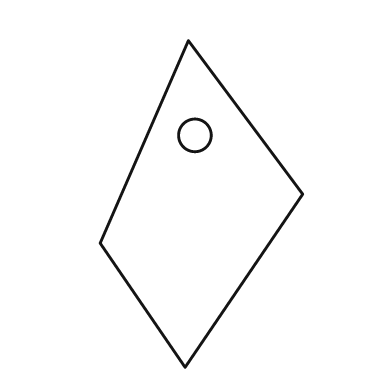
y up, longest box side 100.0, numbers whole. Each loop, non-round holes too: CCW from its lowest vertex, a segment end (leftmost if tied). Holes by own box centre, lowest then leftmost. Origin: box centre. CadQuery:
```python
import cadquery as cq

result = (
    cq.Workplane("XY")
    .moveTo(-5.0, -50.0)
    .lineTo(31.0, 3.0)
    .lineTo(-4.0, 50.0)
    .lineTo(-31.0, -12.0)
    .close()
    .moveTo(-2.0, 21.0)
    .circle(5.0)
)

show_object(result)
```